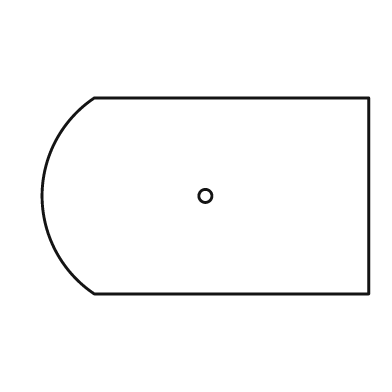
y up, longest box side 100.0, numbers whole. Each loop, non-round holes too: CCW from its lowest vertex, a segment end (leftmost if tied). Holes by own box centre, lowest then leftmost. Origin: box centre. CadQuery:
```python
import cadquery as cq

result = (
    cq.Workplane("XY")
    .moveTo(-34.0, -30.0)
    .lineTo(50.0, -30.0)
    .lineTo(50.0, 30.0)
    .lineTo(-34.0, 30.0)
    .threePointArc((-50.0, 0.0), (-34.0, -30.0))
    .close()
    .moveTo(0.0, 0.0)
    .circle(2.0)
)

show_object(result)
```